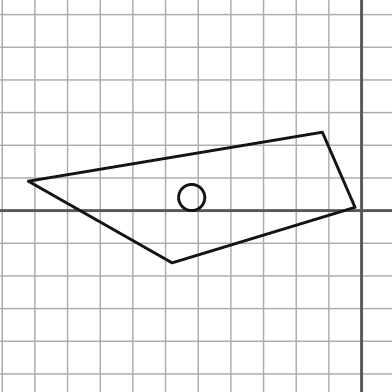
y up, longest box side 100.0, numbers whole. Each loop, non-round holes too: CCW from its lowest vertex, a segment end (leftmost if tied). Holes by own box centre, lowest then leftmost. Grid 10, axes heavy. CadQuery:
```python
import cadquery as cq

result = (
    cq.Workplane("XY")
    .moveTo(-58.0, -16.0)
    .lineTo(-2.0, 1.0)
    .lineTo(-12.0, 24.0)
    .lineTo(-102.0, 9.0)
    .close()
    .moveTo(-52.0, 4.0)
    .circle(4.0)
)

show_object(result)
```